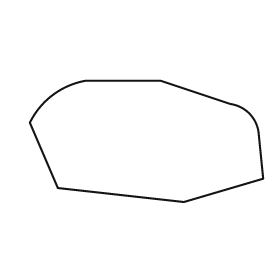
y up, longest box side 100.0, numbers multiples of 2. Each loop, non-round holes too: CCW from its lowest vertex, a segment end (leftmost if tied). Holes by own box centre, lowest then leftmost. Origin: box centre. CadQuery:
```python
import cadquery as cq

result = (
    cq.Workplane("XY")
    .moveTo(16.0, -26.0)
    .lineTo(50.0, -16.0)
    .lineTo(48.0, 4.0)
    .threePointArc((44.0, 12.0), (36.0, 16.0))
    .lineTo(6.0, 26.0)
    .lineTo(-26.0, 26.0)
    .threePointArc((-40.0, 20.0), (-50.0, 8.0))
    .lineTo(-38.0, -20.0)
    .close()
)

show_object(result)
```